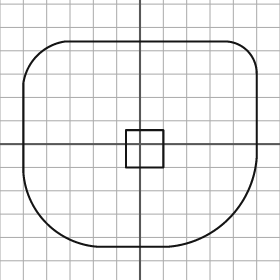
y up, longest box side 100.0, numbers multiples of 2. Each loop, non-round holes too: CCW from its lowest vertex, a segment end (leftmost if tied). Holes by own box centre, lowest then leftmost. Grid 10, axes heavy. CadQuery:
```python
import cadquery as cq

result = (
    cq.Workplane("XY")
    .moveTo(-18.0, -44.0)
    .lineTo(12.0, -44.0)
    .threePointArc((38.0, -32.0), (50.0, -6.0))
    .lineTo(50.0, 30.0)
    .threePointArc((46.0, 40.0), (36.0, 44.0))
    .lineTo(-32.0, 44.0)
    .threePointArc((-44.0, 38.0), (-50.0, 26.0))
    .lineTo(-50.0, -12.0)
    .threePointArc((-40.0, -34.0), (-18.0, -44.0))
    .close()
    .moveTo(-6.0, -10.0)
    .lineTo(10.0, -10.0)
    .lineTo(10.0, 6.0)
    .lineTo(-6.0, 6.0)
    .close()
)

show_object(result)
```